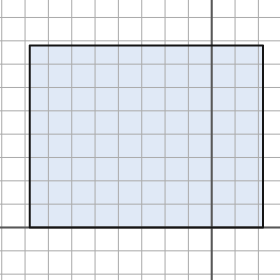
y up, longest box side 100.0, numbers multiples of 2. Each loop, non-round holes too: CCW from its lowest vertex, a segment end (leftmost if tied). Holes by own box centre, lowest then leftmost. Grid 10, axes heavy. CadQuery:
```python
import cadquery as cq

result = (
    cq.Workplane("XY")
    .moveTo(-78.0, 0.0)
    .lineTo(22.0, 0.0)
    .lineTo(22.0, 78.0)
    .lineTo(-78.0, 78.0)
    .close()
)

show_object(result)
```